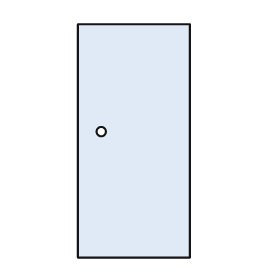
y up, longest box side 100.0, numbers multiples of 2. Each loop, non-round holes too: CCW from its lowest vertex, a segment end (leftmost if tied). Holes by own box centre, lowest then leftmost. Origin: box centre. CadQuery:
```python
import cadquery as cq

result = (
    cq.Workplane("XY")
    .moveTo(-24.0, -50.0)
    .lineTo(24.0, -50.0)
    .lineTo(24.0, 50.0)
    .lineTo(-24.0, 50.0)
    .close()
    .moveTo(-14.0, 4.0)
    .circle(2.0)
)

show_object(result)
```